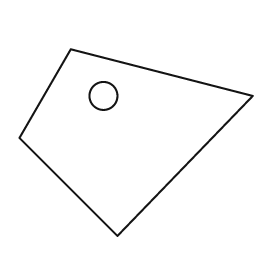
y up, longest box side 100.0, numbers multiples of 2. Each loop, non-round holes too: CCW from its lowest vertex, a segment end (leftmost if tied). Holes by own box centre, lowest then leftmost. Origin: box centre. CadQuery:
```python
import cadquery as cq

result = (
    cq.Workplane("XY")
    .moveTo(-8.0, -40.0)
    .lineTo(50.0, 20.0)
    .lineTo(-28.0, 40.0)
    .lineTo(-50.0, 2.0)
    .close()
    .moveTo(-14.0, 20.0)
    .circle(6.0)
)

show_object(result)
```